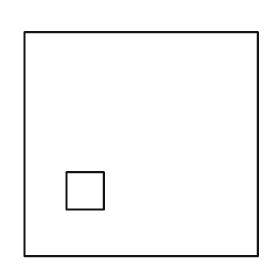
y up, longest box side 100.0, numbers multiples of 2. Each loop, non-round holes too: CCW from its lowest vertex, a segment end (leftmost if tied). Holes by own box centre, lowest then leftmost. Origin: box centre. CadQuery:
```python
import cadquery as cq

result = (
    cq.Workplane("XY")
    .moveTo(-50.0, -48.0)
    .lineTo(50.0, -48.0)
    .lineTo(50.0, 48.0)
    .lineTo(-50.0, 48.0)
    .close()
    .moveTo(-32.0, -28.0)
    .lineTo(-16.0, -28.0)
    .lineTo(-16.0, -12.0)
    .lineTo(-32.0, -12.0)
    .close()
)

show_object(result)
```